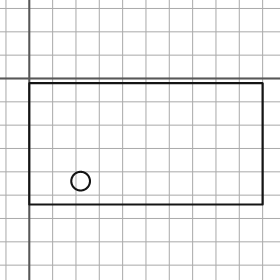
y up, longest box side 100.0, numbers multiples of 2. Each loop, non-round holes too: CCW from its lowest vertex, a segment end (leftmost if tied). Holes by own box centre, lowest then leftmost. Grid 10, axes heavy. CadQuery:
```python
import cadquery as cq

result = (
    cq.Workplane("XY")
    .moveTo(0.0, -54.0)
    .lineTo(100.0, -54.0)
    .lineTo(100.0, -2.0)
    .lineTo(0.0, -2.0)
    .close()
    .moveTo(22.0, -44.0)
    .circle(4.0)
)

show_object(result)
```